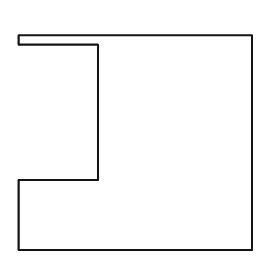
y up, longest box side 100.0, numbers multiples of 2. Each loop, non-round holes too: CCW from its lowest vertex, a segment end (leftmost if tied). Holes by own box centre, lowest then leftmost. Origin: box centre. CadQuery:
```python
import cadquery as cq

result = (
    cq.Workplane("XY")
    .moveTo(-50.0, -46.0)
    .lineTo(50.0, -46.0)
    .lineTo(50.0, 46.0)
    .lineTo(-50.0, 46.0)
    .lineTo(-50.0, 42.0)
    .lineTo(-16.0, 42.0)
    .lineTo(-16.0, -16.0)
    .lineTo(-50.0, -16.0)
    .close()
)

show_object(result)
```